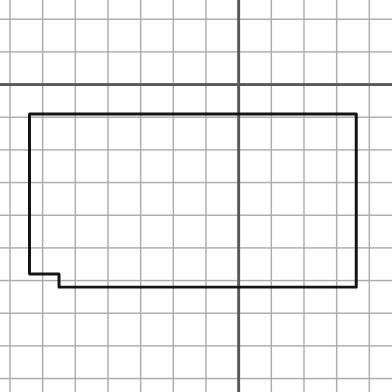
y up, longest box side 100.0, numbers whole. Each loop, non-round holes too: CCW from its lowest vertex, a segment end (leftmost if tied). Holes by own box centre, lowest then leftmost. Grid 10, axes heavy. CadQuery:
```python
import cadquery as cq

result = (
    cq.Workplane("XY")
    .moveTo(-55.0, -62.0)
    .lineTo(36.0, -62.0)
    .lineTo(36.0, -9.0)
    .lineTo(-64.0, -9.0)
    .lineTo(-64.0, -58.0)
    .lineTo(-55.0, -58.0)
    .close()
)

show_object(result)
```